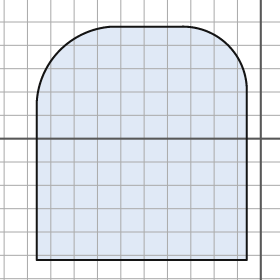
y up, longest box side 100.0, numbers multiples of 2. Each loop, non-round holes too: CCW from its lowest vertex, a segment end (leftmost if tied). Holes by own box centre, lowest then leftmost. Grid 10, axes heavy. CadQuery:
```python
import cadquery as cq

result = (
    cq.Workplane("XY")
    .moveTo(-96.0, -52.0)
    .lineTo(-6.0, -52.0)
    .lineTo(-6.0, 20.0)
    .threePointArc((-14.0, 40.0), (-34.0, 48.0))
    .lineTo(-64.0, 48.0)
    .threePointArc((-86.0, 38.0), (-96.0, 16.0))
    .close()
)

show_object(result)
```